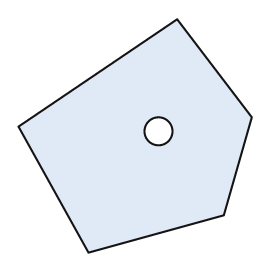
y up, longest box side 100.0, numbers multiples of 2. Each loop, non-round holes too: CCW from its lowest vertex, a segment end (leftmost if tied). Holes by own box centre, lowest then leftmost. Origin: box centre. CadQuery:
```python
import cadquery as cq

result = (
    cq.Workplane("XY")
    .moveTo(-20.0, -50.0)
    .lineTo(38.0, -34.0)
    .lineTo(50.0, 8.0)
    .lineTo(18.0, 50.0)
    .lineTo(-50.0, 4.0)
    .close()
    .moveTo(10.0, 2.0)
    .circle(6.0)
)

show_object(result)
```